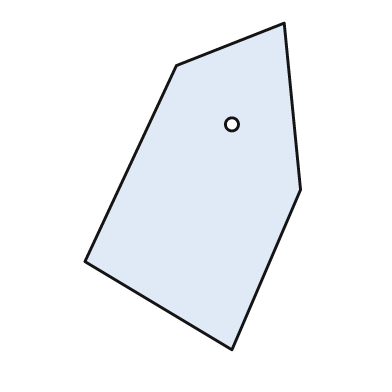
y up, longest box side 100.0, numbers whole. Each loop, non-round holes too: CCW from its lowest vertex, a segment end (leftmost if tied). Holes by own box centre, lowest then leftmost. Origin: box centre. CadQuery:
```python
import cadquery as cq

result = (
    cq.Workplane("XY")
    .moveTo(12.0, -50.0)
    .lineTo(33.0, -1.0)
    .lineTo(28.0, 50.0)
    .lineTo(-5.0, 37.0)
    .lineTo(-33.0, -23.0)
    .close()
    .moveTo(12.0, 19.0)
    .circle(2.0)
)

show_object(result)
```